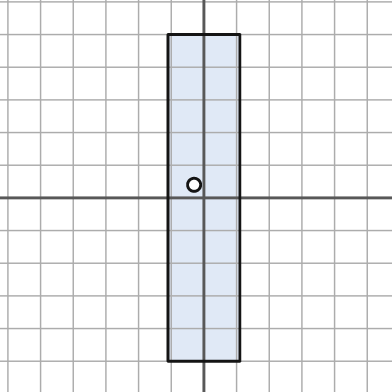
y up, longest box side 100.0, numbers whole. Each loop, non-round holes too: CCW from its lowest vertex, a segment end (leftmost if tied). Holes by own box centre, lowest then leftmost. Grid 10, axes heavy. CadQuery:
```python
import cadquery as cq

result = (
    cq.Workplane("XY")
    .moveTo(-11.0, -50.0)
    .lineTo(11.0, -50.0)
    .lineTo(11.0, 50.0)
    .lineTo(-11.0, 50.0)
    .close()
    .moveTo(-3.0, 4.0)
    .circle(2.0)
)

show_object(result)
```